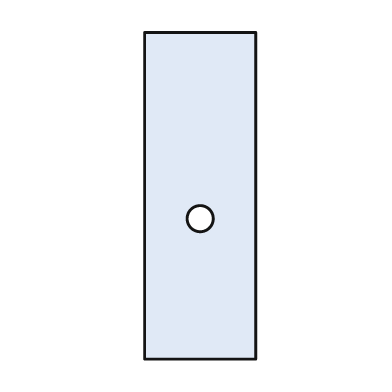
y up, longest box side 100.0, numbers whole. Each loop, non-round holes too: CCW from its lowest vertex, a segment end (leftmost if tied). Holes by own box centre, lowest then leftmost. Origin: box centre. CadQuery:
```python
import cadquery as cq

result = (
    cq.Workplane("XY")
    .moveTo(-17.0, -50.0)
    .lineTo(17.0, -50.0)
    .lineTo(17.0, 50.0)
    .lineTo(-17.0, 50.0)
    .close()
    .moveTo(0.0, -7.0)
    .circle(4.0)
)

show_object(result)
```